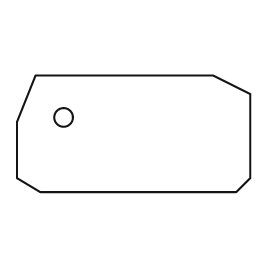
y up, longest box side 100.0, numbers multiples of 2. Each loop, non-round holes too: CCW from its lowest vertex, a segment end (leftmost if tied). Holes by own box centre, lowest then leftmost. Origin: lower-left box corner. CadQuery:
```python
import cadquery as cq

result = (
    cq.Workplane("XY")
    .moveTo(10.0, 0.0)
    .lineTo(94.0, 0.0)
    .lineTo(100.0, 6.0)
    .lineTo(100.0, 42.0)
    .lineTo(84.0, 50.0)
    .lineTo(8.0, 50.0)
    .lineTo(0.0, 30.0)
    .lineTo(0.0, 6.0)
    .close()
    .moveTo(20.0, 32.0)
    .circle(4.0)
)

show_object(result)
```